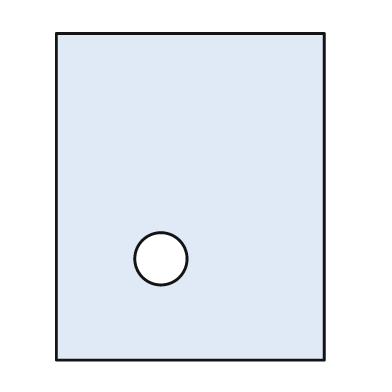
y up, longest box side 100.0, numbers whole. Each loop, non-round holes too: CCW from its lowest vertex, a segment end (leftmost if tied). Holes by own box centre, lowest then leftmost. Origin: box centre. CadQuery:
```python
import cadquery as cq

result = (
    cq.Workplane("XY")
    .moveTo(-41.0, -50.0)
    .lineTo(41.0, -50.0)
    .lineTo(41.0, 50.0)
    .lineTo(-41.0, 50.0)
    .close()
    .moveTo(-9.0, -19.0)
    .circle(8.0)
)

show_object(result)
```